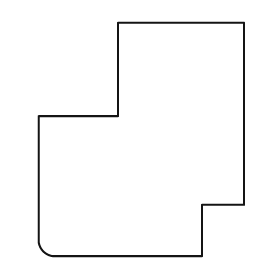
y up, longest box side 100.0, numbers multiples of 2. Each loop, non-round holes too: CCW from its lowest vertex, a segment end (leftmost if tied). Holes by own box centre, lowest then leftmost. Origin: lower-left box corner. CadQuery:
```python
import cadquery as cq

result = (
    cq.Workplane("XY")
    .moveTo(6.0, 0.0)
    .lineTo(70.0, 0.0)
    .lineTo(70.0, 22.0)
    .lineTo(88.0, 22.0)
    .lineTo(88.0, 100.0)
    .lineTo(34.0, 100.0)
    .lineTo(34.0, 60.0)
    .lineTo(0.0, 60.0)
    .lineTo(0.0, 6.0)
    .threePointArc((2.0, 2.0), (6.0, 0.0))
    .close()
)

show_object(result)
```